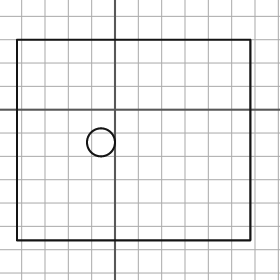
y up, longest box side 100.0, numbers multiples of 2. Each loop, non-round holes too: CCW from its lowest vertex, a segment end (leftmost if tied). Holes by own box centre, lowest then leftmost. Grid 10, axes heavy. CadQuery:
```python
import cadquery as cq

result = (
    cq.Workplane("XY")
    .moveTo(-42.0, -56.0)
    .lineTo(58.0, -56.0)
    .lineTo(58.0, 30.0)
    .lineTo(-42.0, 30.0)
    .close()
    .moveTo(-6.0, -14.0)
    .circle(6.0)
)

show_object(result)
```